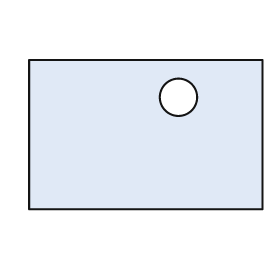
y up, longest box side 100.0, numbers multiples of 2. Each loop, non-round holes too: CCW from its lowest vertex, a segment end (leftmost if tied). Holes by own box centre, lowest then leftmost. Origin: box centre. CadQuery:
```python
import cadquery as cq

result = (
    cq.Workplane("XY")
    .moveTo(-50.0, -32.0)
    .lineTo(50.0, -32.0)
    .lineTo(50.0, 32.0)
    .lineTo(-50.0, 32.0)
    .close()
    .moveTo(14.0, 16.0)
    .circle(8.0)
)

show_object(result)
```